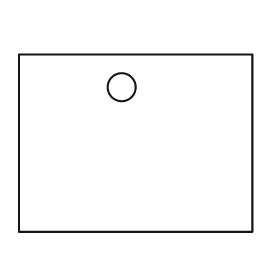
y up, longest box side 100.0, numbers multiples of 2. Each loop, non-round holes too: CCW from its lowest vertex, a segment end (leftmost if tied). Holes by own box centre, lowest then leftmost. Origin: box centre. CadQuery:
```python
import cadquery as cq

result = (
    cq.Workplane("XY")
    .moveTo(-50.0, -38.0)
    .lineTo(50.0, -38.0)
    .lineTo(50.0, 38.0)
    .lineTo(-50.0, 38.0)
    .close()
    .moveTo(-6.0, 24.0)
    .circle(6.0)
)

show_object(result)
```